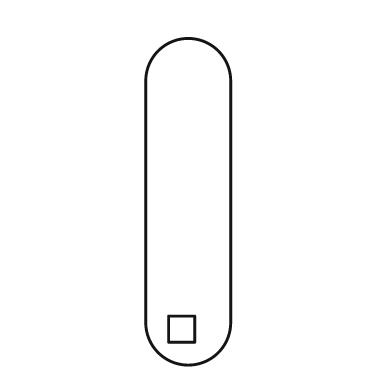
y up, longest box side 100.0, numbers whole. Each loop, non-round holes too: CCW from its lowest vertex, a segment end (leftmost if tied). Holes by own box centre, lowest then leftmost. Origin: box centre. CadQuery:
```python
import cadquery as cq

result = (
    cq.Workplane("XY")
    .moveTo(-13.0, -37.0)
    .threePointArc((0.0, -50.0), (13.0, -37.0))
    .lineTo(13.0, 37.0)
    .threePointArc((0.0, 50.0), (-13.0, 37.0))
    .close()
    .moveTo(-6.0, -43.0)
    .lineTo(2.0, -43.0)
    .lineTo(2.0, -35.0)
    .lineTo(-6.0, -35.0)
    .close()
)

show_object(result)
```